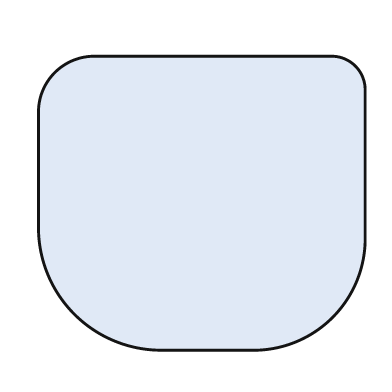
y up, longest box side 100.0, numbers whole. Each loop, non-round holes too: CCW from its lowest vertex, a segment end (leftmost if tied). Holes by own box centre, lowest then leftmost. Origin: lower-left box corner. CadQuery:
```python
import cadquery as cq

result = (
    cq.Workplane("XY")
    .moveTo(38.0, 0.0)
    .lineTo(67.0, 0.0)
    .threePointArc((90.0, 10.0), (100.0, 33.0))
    .lineTo(100.0, 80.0)
    .threePointArc((97.0, 87.0), (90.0, 90.0))
    .lineTo(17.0, 90.0)
    .threePointArc((5.0, 85.0), (0.0, 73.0))
    .lineTo(0.0, 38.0)
    .threePointArc((11.0, 11.0), (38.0, 0.0))
    .close()
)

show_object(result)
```